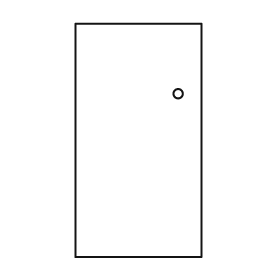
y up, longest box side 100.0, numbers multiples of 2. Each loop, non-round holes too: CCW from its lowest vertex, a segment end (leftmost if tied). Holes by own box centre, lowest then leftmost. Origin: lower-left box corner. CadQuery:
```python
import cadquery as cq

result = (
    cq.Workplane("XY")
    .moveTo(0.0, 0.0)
    .lineTo(54.0, 0.0)
    .lineTo(54.0, 100.0)
    .lineTo(0.0, 100.0)
    .close()
    .moveTo(44.0, 70.0)
    .circle(2.0)
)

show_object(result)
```